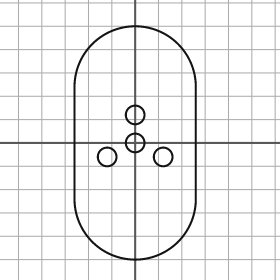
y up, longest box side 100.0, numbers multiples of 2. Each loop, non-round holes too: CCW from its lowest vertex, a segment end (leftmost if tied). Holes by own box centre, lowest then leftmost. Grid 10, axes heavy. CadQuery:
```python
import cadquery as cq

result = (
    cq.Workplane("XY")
    .moveTo(-26.0, -24.0)
    .threePointArc((0.0, -50.0), (26.0, -24.0))
    .lineTo(26.0, 24.0)
    .threePointArc((0.0, 50.0), (-26.0, 24.0))
    .close()
    .moveTo(-12.0, -6.0)
    .circle(4.0)
    .moveTo(12.0, -6.0)
    .circle(4.0)
    .moveTo(0.0, 0.0)
    .circle(4.0)
    .moveTo(0.0, 12.0)
    .circle(4.0)
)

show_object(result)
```